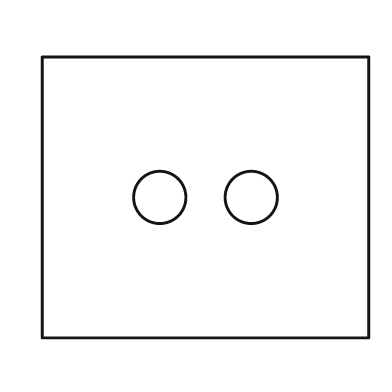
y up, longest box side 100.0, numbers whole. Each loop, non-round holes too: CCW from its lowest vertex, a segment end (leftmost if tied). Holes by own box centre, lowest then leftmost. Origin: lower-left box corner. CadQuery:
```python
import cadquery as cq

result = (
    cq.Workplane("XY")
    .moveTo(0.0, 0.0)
    .lineTo(100.0, 0.0)
    .lineTo(100.0, 86.0)
    .lineTo(0.0, 86.0)
    .close()
    .moveTo(36.0, 43.0)
    .circle(8.0)
    .moveTo(64.0, 43.0)
    .circle(8.0)
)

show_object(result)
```